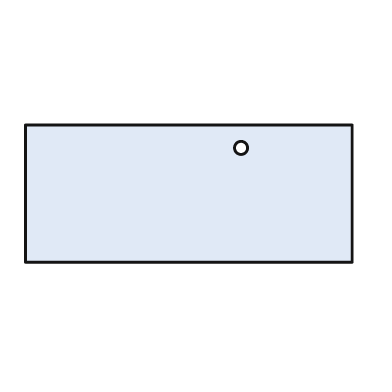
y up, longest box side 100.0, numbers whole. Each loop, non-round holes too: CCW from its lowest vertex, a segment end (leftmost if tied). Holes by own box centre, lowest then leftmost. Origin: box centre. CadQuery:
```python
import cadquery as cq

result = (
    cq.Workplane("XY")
    .moveTo(-50.0, -21.0)
    .lineTo(50.0, -21.0)
    .lineTo(50.0, 21.0)
    .lineTo(-50.0, 21.0)
    .close()
    .moveTo(16.0, 14.0)
    .circle(2.0)
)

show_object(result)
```